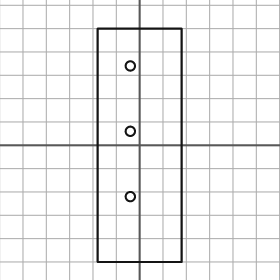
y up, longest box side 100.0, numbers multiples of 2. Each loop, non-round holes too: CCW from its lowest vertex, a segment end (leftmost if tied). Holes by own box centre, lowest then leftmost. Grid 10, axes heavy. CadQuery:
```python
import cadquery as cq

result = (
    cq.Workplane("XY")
    .moveTo(-18.0, -50.0)
    .lineTo(18.0, -50.0)
    .lineTo(18.0, 50.0)
    .lineTo(-18.0, 50.0)
    .close()
    .moveTo(-4.0, -22.0)
    .circle(2.0)
    .moveTo(-4.0, 6.0)
    .circle(2.0)
    .moveTo(-4.0, 34.0)
    .circle(2.0)
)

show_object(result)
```